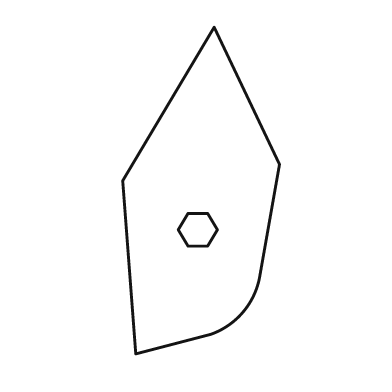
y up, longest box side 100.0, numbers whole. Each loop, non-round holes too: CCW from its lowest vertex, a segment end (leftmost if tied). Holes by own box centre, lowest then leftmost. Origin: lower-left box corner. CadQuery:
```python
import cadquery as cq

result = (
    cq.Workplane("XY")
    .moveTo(4.0, 0.0)
    .lineTo(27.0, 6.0)
    .threePointArc((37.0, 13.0), (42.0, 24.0))
    .lineTo(48.0, 58.0)
    .lineTo(28.0, 100.0)
    .lineTo(0.0, 53.0)
    .close()
    .moveTo(20.0, 33.0)
    .lineTo(26.0, 33.0)
    .lineTo(29.0, 38.0)
    .lineTo(26.0, 43.0)
    .lineTo(20.0, 43.0)
    .lineTo(17.0, 38.0)
    .close()
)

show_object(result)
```